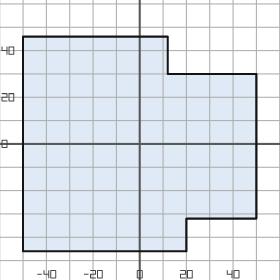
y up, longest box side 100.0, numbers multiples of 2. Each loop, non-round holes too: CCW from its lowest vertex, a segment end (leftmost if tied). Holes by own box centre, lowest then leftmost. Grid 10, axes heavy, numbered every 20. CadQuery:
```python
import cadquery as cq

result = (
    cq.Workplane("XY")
    .moveTo(-50.0, -46.0)
    .lineTo(20.0, -46.0)
    .lineTo(20.0, -32.0)
    .lineTo(50.0, -32.0)
    .lineTo(50.0, 30.0)
    .lineTo(12.0, 30.0)
    .lineTo(12.0, 46.0)
    .lineTo(-50.0, 46.0)
    .close()
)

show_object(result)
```